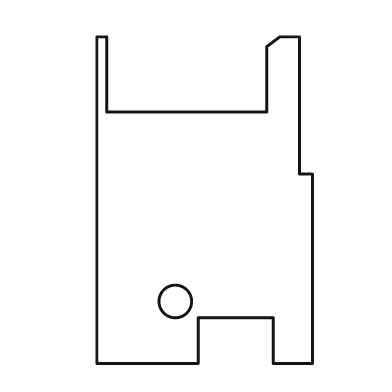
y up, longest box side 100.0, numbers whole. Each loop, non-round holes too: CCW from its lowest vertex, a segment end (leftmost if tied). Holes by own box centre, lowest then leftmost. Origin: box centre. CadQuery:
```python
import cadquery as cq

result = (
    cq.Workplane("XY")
    .moveTo(-33.0, -50.0)
    .lineTo(-2.0, -50.0)
    .lineTo(-2.0, -36.0)
    .lineTo(21.0, -36.0)
    .lineTo(21.0, -50.0)
    .lineTo(33.0, -50.0)
    .lineTo(33.0, 8.0)
    .lineTo(29.0, 8.0)
    .lineTo(29.0, 50.0)
    .lineTo(23.0, 50.0)
    .lineTo(19.0, 47.0)
    .lineTo(19.0, 27.0)
    .lineTo(-30.0, 27.0)
    .lineTo(-30.0, 50.0)
    .lineTo(-33.0, 50.0)
    .close()
    .moveTo(-9.0, -31.0)
    .circle(5.0)
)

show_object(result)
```